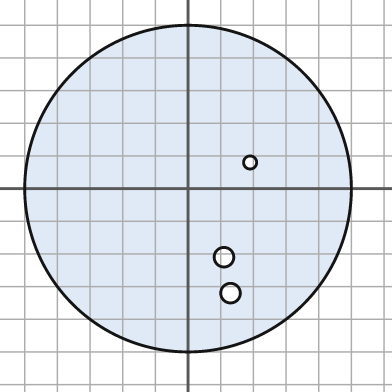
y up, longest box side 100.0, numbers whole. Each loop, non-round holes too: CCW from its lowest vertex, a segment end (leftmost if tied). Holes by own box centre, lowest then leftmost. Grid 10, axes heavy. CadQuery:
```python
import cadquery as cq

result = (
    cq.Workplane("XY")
    .moveTo(0.0, 0.0)
    .circle(50.0)
    .moveTo(13.0, -32.0)
    .circle(3.0)
    .moveTo(11.0, -21.0)
    .circle(3.0)
    .moveTo(19.0, 8.0)
    .circle(2.0)
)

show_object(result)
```